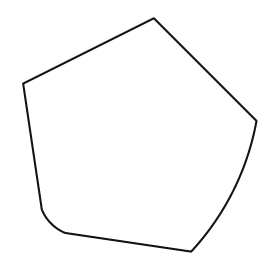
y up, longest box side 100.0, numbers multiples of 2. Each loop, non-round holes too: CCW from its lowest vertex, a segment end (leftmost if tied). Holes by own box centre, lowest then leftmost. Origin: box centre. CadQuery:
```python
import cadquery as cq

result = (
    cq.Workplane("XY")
    .moveTo(22.0, -50.0)
    .threePointArc((40.0, -24.0), (50.0, 6.0))
    .lineTo(6.0, 50.0)
    .lineTo(-50.0, 22.0)
    .lineTo(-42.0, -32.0)
    .threePointArc((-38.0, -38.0), (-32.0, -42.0))
    .close()
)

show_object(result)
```